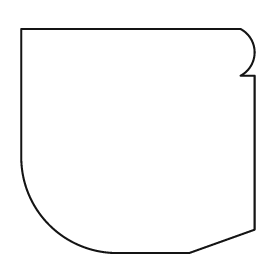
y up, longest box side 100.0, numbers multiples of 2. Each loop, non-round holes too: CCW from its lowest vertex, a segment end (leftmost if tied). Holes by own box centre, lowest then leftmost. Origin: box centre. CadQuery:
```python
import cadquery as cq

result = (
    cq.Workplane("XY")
    .moveTo(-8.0, -48.0)
    .lineTo(22.0, -48.0)
    .lineTo(50.0, -38.0)
    .lineTo(50.0, 28.0)
    .lineTo(44.0, 28.0)
    .threePointArc((50.0, 38.0), (44.0, 48.0))
    .lineTo(-50.0, 48.0)
    .lineTo(-50.0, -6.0)
    .threePointArc((-38.0, -36.0), (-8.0, -48.0))
    .close()
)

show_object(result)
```